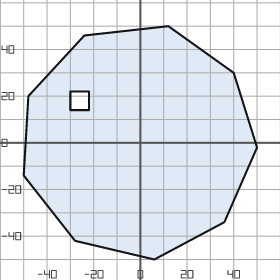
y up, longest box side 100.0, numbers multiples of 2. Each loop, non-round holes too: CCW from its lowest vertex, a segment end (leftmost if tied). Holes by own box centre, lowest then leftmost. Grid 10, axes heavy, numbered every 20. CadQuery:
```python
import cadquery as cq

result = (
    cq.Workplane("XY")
    .moveTo(6.0, -50.0)
    .lineTo(36.0, -34.0)
    .lineTo(50.0, -2.0)
    .lineTo(40.0, 30.0)
    .lineTo(12.0, 50.0)
    .lineTo(-24.0, 46.0)
    .lineTo(-48.0, 20.0)
    .lineTo(-50.0, -14.0)
    .lineTo(-28.0, -42.0)
    .close()
    .moveTo(-30.0, 14.0)
    .lineTo(-22.0, 14.0)
    .lineTo(-22.0, 22.0)
    .lineTo(-30.0, 22.0)
    .close()
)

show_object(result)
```